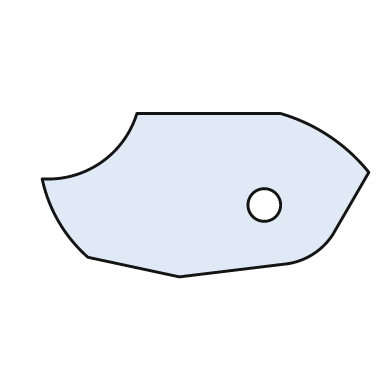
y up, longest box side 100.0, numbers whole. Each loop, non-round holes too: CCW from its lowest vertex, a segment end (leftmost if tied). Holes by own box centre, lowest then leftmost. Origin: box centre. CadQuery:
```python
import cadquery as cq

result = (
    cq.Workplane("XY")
    .moveTo(-8.0, -25.0)
    .lineTo(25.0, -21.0)
    .threePointArc((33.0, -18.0), (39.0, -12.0))
    .lineTo(50.0, 7.0)
    .threePointArc((38.0, 18.0), (23.0, 25.0))
    .lineTo(-21.0, 25.0)
    .threePointArc((-32.0, 10.0), (-50.0, 5.0))
    .threePointArc((-45.0, -8.0), (-36.0, -19.0))
    .close()
    .moveTo(18.0, -3.0)
    .circle(5.0)
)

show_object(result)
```